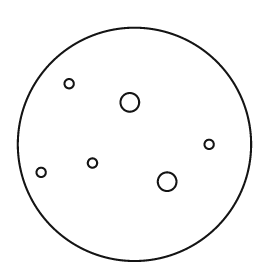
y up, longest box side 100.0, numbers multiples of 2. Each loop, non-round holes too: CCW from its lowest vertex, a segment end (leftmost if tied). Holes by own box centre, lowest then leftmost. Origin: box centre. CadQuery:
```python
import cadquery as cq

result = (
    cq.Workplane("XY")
    .moveTo(0.0, 0.0)
    .circle(50.0)
    .moveTo(14.0, -16.0)
    .circle(4.0)
    .moveTo(-40.0, -12.0)
    .circle(2.0)
    .moveTo(-18.0, -8.0)
    .circle(2.0)
    .moveTo(32.0, 0.0)
    .circle(2.0)
    .moveTo(-2.0, 18.0)
    .circle(4.0)
    .moveTo(-28.0, 26.0)
    .circle(2.0)
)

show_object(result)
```